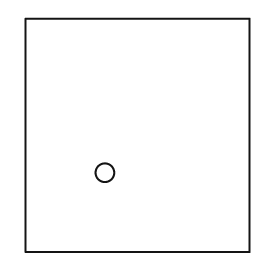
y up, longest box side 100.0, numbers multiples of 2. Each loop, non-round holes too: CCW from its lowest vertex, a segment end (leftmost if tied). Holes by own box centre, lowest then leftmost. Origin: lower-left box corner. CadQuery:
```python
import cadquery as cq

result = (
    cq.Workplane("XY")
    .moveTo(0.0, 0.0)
    .lineTo(96.0, 0.0)
    .lineTo(96.0, 100.0)
    .lineTo(0.0, 100.0)
    .close()
    .moveTo(34.0, 34.0)
    .circle(4.0)
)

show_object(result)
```